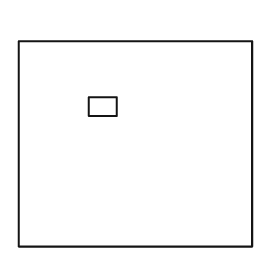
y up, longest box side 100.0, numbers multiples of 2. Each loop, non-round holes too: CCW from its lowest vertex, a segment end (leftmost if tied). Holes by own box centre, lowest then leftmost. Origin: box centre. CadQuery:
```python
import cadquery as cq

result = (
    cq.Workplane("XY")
    .moveTo(-50.0, -44.0)
    .lineTo(50.0, -44.0)
    .lineTo(50.0, 44.0)
    .lineTo(-50.0, 44.0)
    .close()
    .moveTo(-20.0, 12.0)
    .lineTo(-8.0, 12.0)
    .lineTo(-8.0, 20.0)
    .lineTo(-20.0, 20.0)
    .close()
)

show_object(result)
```